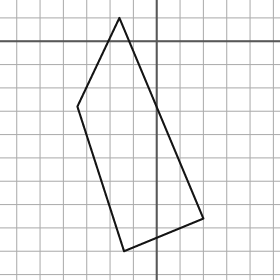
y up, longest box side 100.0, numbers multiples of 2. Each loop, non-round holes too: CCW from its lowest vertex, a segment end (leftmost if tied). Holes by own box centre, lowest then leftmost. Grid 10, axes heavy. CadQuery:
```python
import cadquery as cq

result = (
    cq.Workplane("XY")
    .moveTo(-14.0, -90.0)
    .lineTo(20.0, -76.0)
    .lineTo(-16.0, 10.0)
    .lineTo(-34.0, -28.0)
    .close()
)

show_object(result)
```